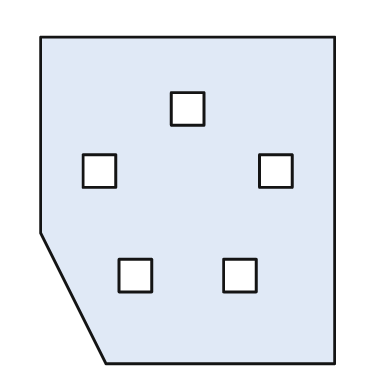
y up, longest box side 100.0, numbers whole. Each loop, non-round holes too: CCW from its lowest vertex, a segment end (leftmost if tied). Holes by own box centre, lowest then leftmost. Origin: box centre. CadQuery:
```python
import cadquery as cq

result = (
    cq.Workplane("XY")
    .moveTo(-25.0, -50.0)
    .lineTo(45.0, -50.0)
    .lineTo(45.0, 50.0)
    .lineTo(-45.0, 50.0)
    .lineTo(-45.0, -10.0)
    .close()
    .moveTo(-21.0, -28.0)
    .lineTo(-11.0, -28.0)
    .lineTo(-11.0, -18.0)
    .lineTo(-21.0, -18.0)
    .close()
    .moveTo(11.0, -28.0)
    .lineTo(21.0, -28.0)
    .lineTo(21.0, -18.0)
    .lineTo(11.0, -18.0)
    .close()
    .moveTo(-32.0, 4.0)
    .lineTo(-22.0, 4.0)
    .lineTo(-22.0, 14.0)
    .lineTo(-32.0, 14.0)
    .close()
    .moveTo(22.0, 4.0)
    .lineTo(32.0, 4.0)
    .lineTo(32.0, 14.0)
    .lineTo(22.0, 14.0)
    .close()
    .moveTo(-5.0, 23.0)
    .lineTo(5.0, 23.0)
    .lineTo(5.0, 33.0)
    .lineTo(-5.0, 33.0)
    .close()
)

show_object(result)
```